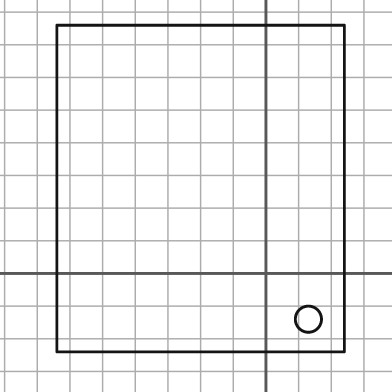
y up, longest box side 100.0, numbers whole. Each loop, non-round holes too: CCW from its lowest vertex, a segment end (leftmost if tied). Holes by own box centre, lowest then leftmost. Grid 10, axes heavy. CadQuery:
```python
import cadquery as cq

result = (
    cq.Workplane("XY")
    .moveTo(-64.0, -24.0)
    .lineTo(24.0, -24.0)
    .lineTo(24.0, 76.0)
    .lineTo(-64.0, 76.0)
    .close()
    .moveTo(13.0, -14.0)
    .circle(4.0)
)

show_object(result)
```